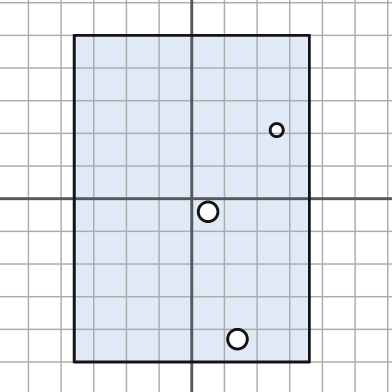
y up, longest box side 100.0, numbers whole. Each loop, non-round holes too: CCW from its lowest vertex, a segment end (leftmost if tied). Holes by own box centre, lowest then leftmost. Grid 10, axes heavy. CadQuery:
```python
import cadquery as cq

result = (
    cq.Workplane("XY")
    .moveTo(-36.0, -50.0)
    .lineTo(36.0, -50.0)
    .lineTo(36.0, 50.0)
    .lineTo(-36.0, 50.0)
    .close()
    .moveTo(14.0, -43.0)
    .circle(3.0)
    .moveTo(5.0, -4.0)
    .circle(3.0)
    .moveTo(26.0, 21.0)
    .circle(2.0)
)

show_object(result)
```